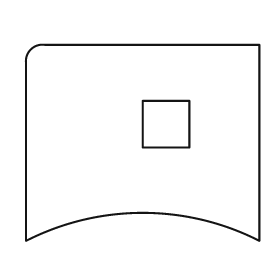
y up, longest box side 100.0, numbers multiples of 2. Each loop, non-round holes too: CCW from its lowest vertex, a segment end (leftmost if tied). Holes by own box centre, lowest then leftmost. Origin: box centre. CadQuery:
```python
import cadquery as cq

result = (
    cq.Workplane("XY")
    .moveTo(-50.0, -42.0)
    .threePointArc((0.0, -30.0), (50.0, -42.0))
    .lineTo(50.0, 42.0)
    .lineTo(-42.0, 42.0)
    .threePointArc((-48.0, 40.0), (-50.0, 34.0))
    .close()
    .moveTo(0.0, -2.0)
    .lineTo(20.0, -2.0)
    .lineTo(20.0, 18.0)
    .lineTo(0.0, 18.0)
    .close()
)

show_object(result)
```